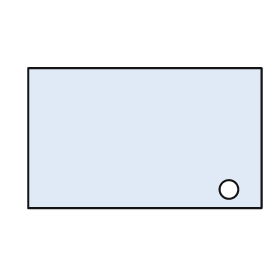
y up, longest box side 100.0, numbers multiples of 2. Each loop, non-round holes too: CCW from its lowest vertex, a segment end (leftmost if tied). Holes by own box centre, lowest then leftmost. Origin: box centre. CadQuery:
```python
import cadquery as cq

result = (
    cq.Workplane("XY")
    .moveTo(-50.0, -30.0)
    .lineTo(50.0, -30.0)
    .lineTo(50.0, 30.0)
    .lineTo(-50.0, 30.0)
    .close()
    .moveTo(36.0, -22.0)
    .circle(4.0)
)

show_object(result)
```